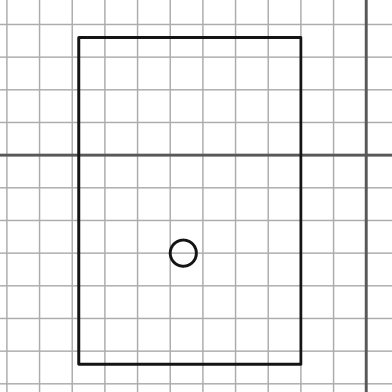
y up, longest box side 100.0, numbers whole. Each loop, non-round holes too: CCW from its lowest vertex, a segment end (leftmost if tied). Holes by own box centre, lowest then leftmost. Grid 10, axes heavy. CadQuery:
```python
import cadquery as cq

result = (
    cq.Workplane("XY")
    .moveTo(-88.0, -64.0)
    .lineTo(-20.0, -64.0)
    .lineTo(-20.0, 36.0)
    .lineTo(-88.0, 36.0)
    .close()
    .moveTo(-56.0, -30.0)
    .circle(4.0)
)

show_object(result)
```